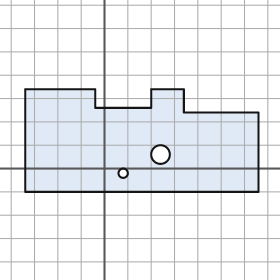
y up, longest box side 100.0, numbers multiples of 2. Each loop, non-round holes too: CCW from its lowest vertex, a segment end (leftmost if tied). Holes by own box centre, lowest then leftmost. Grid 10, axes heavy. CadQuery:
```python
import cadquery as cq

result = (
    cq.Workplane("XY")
    .moveTo(-34.0, -10.0)
    .lineTo(66.0, -10.0)
    .lineTo(66.0, 24.0)
    .lineTo(34.0, 24.0)
    .lineTo(34.0, 34.0)
    .lineTo(20.0, 34.0)
    .lineTo(20.0, 26.0)
    .lineTo(-4.0, 26.0)
    .lineTo(-4.0, 34.0)
    .lineTo(-34.0, 34.0)
    .close()
    .moveTo(8.0, -2.0)
    .circle(2.0)
    .moveTo(24.0, 6.0)
    .circle(4.0)
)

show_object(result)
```